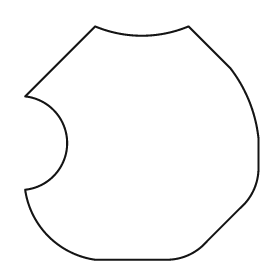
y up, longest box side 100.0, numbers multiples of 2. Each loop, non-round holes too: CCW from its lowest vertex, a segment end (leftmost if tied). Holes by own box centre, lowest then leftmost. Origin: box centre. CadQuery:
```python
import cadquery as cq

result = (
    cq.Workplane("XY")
    .moveTo(-20.0, -50.0)
    .lineTo(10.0, -50.0)
    .threePointArc((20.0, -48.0), (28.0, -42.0))
    .lineTo(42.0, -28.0)
    .threePointArc((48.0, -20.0), (50.0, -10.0))
    .lineTo(50.0, 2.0)
    .threePointArc((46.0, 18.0), (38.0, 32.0))
    .lineTo(20.0, 50.0)
    .threePointArc((0.0, 46.0), (-20.0, 50.0))
    .lineTo(-50.0, 20.0)
    .threePointArc((-32.0, 0.0), (-50.0, -20.0))
    .threePointArc((-40.0, -40.0), (-20.0, -50.0))
    .close()
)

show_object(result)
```